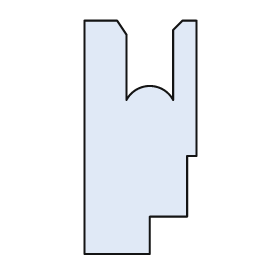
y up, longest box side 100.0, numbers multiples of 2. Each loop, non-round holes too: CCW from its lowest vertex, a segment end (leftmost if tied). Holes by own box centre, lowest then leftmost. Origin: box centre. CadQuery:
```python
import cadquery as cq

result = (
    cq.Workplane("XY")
    .moveTo(-24.0, -50.0)
    .lineTo(4.0, -50.0)
    .lineTo(4.0, -34.0)
    .lineTo(20.0, -34.0)
    .lineTo(20.0, -8.0)
    .lineTo(24.0, -8.0)
    .lineTo(24.0, 50.0)
    .lineTo(18.0, 50.0)
    .lineTo(14.0, 46.0)
    .lineTo(14.0, 16.0)
    .threePointArc((4.0, 22.0), (-6.0, 16.0))
    .lineTo(-6.0, 44.0)
    .lineTo(-10.0, 50.0)
    .lineTo(-24.0, 50.0)
    .close()
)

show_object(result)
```